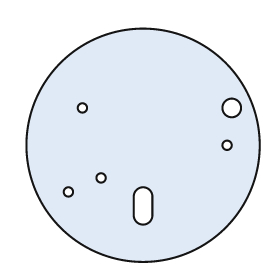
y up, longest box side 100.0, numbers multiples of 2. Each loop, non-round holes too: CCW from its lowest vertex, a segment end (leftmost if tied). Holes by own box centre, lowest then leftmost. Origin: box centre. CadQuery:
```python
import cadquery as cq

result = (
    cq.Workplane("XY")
    .moveTo(0.0, 0.0)
    .circle(50.0)
    .moveTo(-4.0, -30.0)
    .threePointArc((0.0, -34.0), (4.0, -30.0))
    .lineTo(4.0, -22.0)
    .threePointArc((0.0, -18.0), (-4.0, -22.0))
    .close()
    .moveTo(-32.0, -20.0)
    .circle(2.0)
    .moveTo(-18.0, -14.0)
    .circle(2.0)
    .moveTo(36.0, 0.0)
    .circle(2.0)
    .moveTo(-26.0, 16.0)
    .circle(2.0)
    .moveTo(38.0, 16.0)
    .circle(4.0)
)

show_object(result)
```